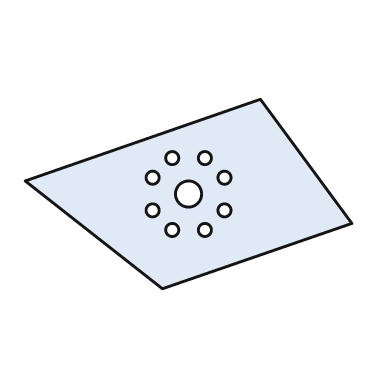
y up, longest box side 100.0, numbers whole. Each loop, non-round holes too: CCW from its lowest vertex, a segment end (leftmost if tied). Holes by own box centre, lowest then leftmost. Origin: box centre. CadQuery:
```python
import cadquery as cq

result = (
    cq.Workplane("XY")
    .moveTo(-8.0, -29.0)
    .lineTo(50.0, -9.0)
    .lineTo(22.0, 29.0)
    .lineTo(-50.0, 4.0)
    .close()
    .moveTo(-5.0, -11.0)
    .circle(2.0)
    .moveTo(5.0, -11.0)
    .circle(2.0)
    .moveTo(-11.0, -5.0)
    .circle(2.0)
    .moveTo(11.0, -5.0)
    .circle(2.0)
    .moveTo(0.0, 0.0)
    .circle(4.0)
    .moveTo(-11.0, 5.0)
    .circle(2.0)
    .moveTo(11.0, 5.0)
    .circle(2.0)
    .moveTo(-5.0, 11.0)
    .circle(2.0)
    .moveTo(5.0, 11.0)
    .circle(2.0)
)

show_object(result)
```